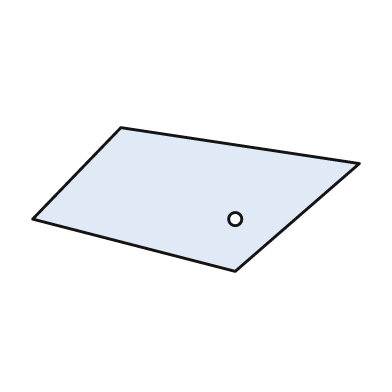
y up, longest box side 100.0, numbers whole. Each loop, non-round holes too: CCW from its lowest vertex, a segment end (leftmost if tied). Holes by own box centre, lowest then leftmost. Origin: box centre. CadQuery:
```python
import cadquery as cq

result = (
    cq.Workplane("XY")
    .moveTo(12.0, -22.0)
    .lineTo(50.0, 11.0)
    .lineTo(-23.0, 22.0)
    .lineTo(-50.0, -6.0)
    .close()
    .moveTo(12.0, -6.0)
    .circle(2.0)
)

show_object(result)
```